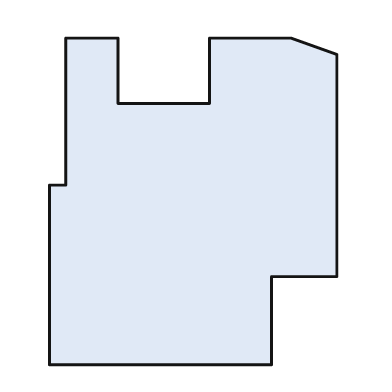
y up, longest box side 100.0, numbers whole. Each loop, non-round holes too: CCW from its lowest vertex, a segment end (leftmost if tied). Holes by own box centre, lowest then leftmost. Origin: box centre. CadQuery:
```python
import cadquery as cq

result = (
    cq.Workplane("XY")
    .moveTo(-44.0, -50.0)
    .lineTo(24.0, -50.0)
    .lineTo(24.0, -23.0)
    .lineTo(44.0, -23.0)
    .lineTo(44.0, 45.0)
    .lineTo(30.0, 50.0)
    .lineTo(5.0, 50.0)
    .lineTo(5.0, 30.0)
    .lineTo(-23.0, 30.0)
    .lineTo(-23.0, 50.0)
    .lineTo(-39.0, 50.0)
    .lineTo(-39.0, 5.0)
    .lineTo(-44.0, 5.0)
    .close()
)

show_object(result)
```